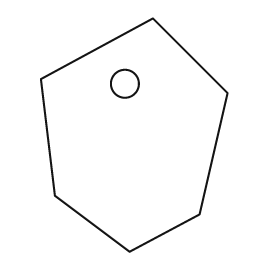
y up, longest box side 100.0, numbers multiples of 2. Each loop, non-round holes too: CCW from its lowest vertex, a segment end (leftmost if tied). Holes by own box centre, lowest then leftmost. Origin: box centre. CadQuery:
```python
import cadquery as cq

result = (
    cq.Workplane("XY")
    .moveTo(-2.0, -50.0)
    .lineTo(28.0, -34.0)
    .lineTo(40.0, 18.0)
    .lineTo(8.0, 50.0)
    .lineTo(-40.0, 24.0)
    .lineTo(-34.0, -26.0)
    .close()
    .moveTo(-4.0, 22.0)
    .circle(6.0)
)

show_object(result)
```